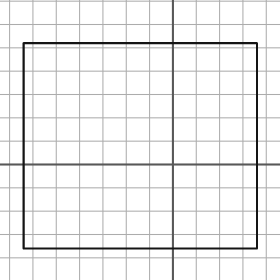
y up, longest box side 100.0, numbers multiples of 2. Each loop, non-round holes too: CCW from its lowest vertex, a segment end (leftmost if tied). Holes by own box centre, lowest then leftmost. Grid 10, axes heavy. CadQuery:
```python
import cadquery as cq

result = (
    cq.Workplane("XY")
    .moveTo(-64.0, -36.0)
    .lineTo(36.0, -36.0)
    .lineTo(36.0, 52.0)
    .lineTo(-64.0, 52.0)
    .close()
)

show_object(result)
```